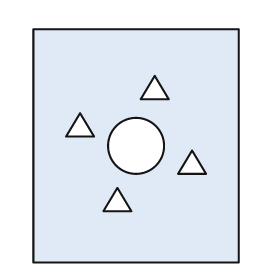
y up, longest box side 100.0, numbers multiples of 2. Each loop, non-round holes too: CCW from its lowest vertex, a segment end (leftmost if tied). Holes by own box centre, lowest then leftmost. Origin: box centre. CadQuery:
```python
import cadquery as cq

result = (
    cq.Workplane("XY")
    .moveTo(-44.0, -50.0)
    .lineTo(44.0, -50.0)
    .lineTo(44.0, 50.0)
    .lineTo(-44.0, 50.0)
    .close()
    .moveTo(-14.0, -28.0)
    .lineTo(-2.0, -28.0)
    .lineTo(-8.0, -18.0)
    .close()
    .moveTo(18.0, -12.0)
    .lineTo(30.0, -12.0)
    .lineTo(24.0, -2.0)
    .close()
    .moveTo(0.0, 0.0)
    .circle(12.0)
    .moveTo(-30.0, 4.0)
    .lineTo(-18.0, 4.0)
    .lineTo(-24.0, 14.0)
    .close()
    .moveTo(2.0, 20.0)
    .lineTo(14.0, 20.0)
    .lineTo(8.0, 30.0)
    .close()
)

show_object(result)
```